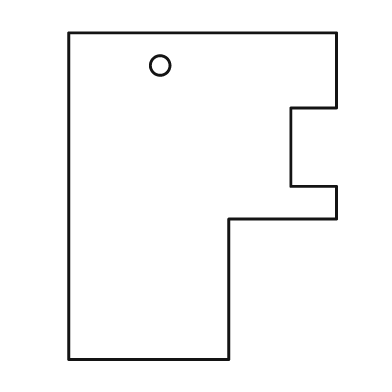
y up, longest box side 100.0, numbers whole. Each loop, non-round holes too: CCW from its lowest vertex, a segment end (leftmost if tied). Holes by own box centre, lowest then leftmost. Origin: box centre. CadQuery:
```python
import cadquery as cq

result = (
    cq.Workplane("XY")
    .moveTo(-41.0, -50.0)
    .lineTo(8.0, -50.0)
    .lineTo(8.0, -7.0)
    .lineTo(41.0, -7.0)
    .lineTo(41.0, 3.0)
    .lineTo(27.0, 3.0)
    .lineTo(27.0, 27.0)
    .lineTo(41.0, 27.0)
    .lineTo(41.0, 50.0)
    .lineTo(-41.0, 50.0)
    .close()
    .moveTo(-13.0, 40.0)
    .circle(3.0)
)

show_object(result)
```